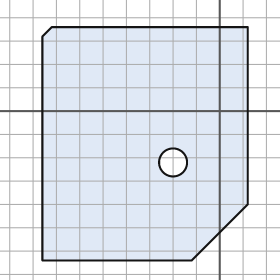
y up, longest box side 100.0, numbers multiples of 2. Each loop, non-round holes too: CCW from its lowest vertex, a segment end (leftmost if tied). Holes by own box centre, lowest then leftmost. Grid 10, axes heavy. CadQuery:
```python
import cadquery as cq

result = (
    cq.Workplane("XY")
    .moveTo(-76.0, -64.0)
    .lineTo(-12.0, -64.0)
    .lineTo(12.0, -40.0)
    .lineTo(12.0, 36.0)
    .lineTo(-72.0, 36.0)
    .lineTo(-76.0, 32.0)
    .close()
    .moveTo(-20.0, -22.0)
    .circle(6.0)
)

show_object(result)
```